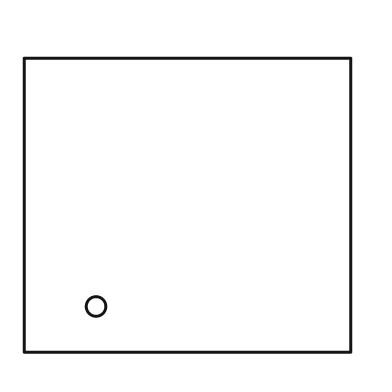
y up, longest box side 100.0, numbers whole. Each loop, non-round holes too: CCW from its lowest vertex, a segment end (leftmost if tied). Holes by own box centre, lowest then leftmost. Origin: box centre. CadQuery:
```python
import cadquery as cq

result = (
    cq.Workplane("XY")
    .moveTo(-50.0, -45.0)
    .lineTo(50.0, -45.0)
    .lineTo(50.0, 45.0)
    .lineTo(-50.0, 45.0)
    .close()
    .moveTo(-28.0, -31.0)
    .circle(3.0)
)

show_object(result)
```